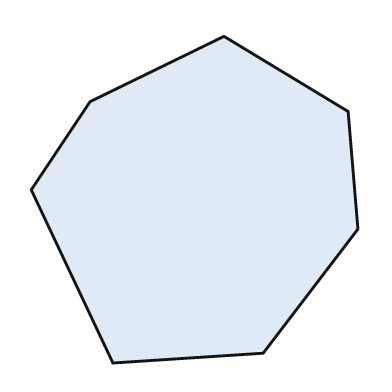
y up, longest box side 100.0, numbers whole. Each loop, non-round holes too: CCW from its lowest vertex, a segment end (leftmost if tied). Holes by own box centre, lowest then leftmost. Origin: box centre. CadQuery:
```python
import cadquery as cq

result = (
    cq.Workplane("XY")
    .moveTo(-25.0, -50.0)
    .lineTo(21.0, -47.0)
    .lineTo(50.0, -9.0)
    .lineTo(47.0, 27.0)
    .lineTo(9.0, 50.0)
    .lineTo(-32.0, 30.0)
    .lineTo(-50.0, 3.0)
    .close()
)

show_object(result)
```